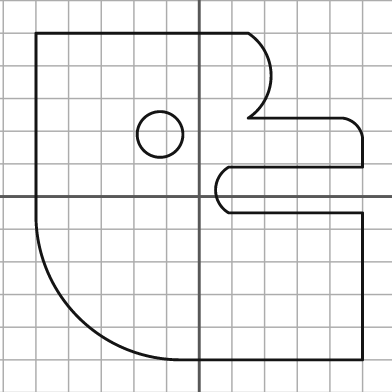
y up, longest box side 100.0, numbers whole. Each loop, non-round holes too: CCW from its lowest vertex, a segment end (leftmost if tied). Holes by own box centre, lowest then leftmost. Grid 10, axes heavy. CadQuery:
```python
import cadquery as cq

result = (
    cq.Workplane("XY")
    .moveTo(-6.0, -50.0)
    .lineTo(50.0, -50.0)
    .lineTo(50.0, -5.0)
    .lineTo(9.0, -5.0)
    .threePointArc((5.0, 2.0), (9.0, 9.0))
    .lineTo(50.0, 9.0)
    .lineTo(50.0, 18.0)
    .threePointArc((48.0, 22.0), (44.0, 24.0))
    .lineTo(15.0, 24.0)
    .threePointArc((22.0, 37.0), (15.0, 50.0))
    .lineTo(-50.0, 50.0)
    .lineTo(-50.0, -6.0)
    .threePointArc((-37.0, -37.0), (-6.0, -50.0))
    .close()
    .moveTo(-12.0, 19.0)
    .circle(7.0)
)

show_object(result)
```